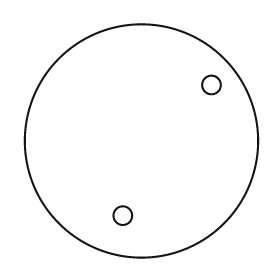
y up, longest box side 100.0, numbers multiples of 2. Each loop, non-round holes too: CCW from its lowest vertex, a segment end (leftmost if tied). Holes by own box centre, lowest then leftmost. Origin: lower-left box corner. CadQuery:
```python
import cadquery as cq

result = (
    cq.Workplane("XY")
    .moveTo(50.0, 50.0)
    .circle(50.0)
    .moveTo(42.0, 18.0)
    .circle(4.0)
    .moveTo(80.0, 74.0)
    .circle(4.0)
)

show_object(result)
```